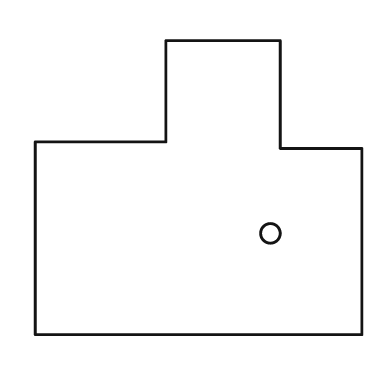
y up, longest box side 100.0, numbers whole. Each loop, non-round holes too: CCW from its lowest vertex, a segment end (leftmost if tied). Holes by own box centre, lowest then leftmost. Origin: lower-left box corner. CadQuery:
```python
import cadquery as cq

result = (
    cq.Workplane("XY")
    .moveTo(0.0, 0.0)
    .lineTo(100.0, 0.0)
    .lineTo(100.0, 57.0)
    .lineTo(75.0, 57.0)
    .lineTo(75.0, 90.0)
    .lineTo(40.0, 90.0)
    .lineTo(40.0, 59.0)
    .lineTo(0.0, 59.0)
    .close()
    .moveTo(72.0, 31.0)
    .circle(3.0)
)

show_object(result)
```